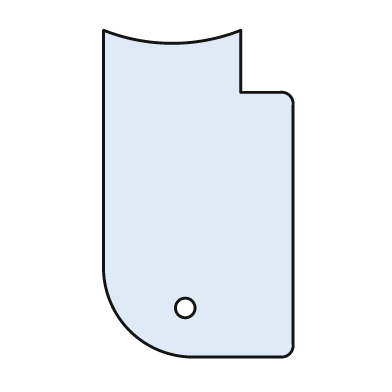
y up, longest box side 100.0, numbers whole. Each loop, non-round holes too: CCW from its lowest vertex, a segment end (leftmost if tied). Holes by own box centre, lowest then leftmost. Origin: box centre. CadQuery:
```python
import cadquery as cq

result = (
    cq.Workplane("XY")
    .moveTo(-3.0, -50.0)
    .lineTo(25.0, -50.0)
    .threePointArc((28.0, -49.0), (29.0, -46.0))
    .lineTo(29.0, 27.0)
    .threePointArc((28.0, 30.0), (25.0, 31.0))
    .lineTo(13.0, 31.0)
    .lineTo(13.0, 50.0)
    .threePointArc((-8.0, 46.0), (-29.0, 50.0))
    .lineTo(-29.0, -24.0)
    .threePointArc((-21.0, -42.0), (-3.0, -50.0))
    .close()
    .moveTo(-4.0, -35.0)
    .circle(3.0)
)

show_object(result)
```